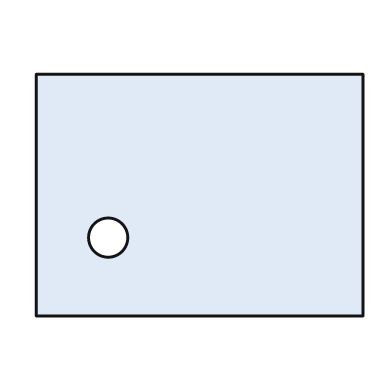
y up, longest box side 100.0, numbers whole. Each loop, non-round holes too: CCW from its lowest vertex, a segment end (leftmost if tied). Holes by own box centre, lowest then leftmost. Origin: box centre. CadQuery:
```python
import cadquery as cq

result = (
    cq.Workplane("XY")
    .moveTo(-50.0, -37.0)
    .lineTo(50.0, -37.0)
    .lineTo(50.0, 37.0)
    .lineTo(-50.0, 37.0)
    .close()
    .moveTo(-28.0, -13.0)
    .circle(6.0)
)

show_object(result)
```